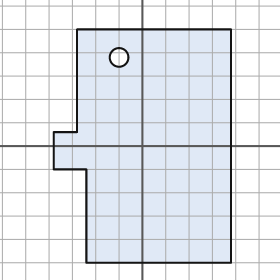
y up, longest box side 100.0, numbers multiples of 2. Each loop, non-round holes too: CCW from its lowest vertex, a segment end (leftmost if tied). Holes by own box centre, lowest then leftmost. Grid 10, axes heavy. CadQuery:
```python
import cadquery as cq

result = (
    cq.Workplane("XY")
    .moveTo(-24.0, -50.0)
    .lineTo(38.0, -50.0)
    .lineTo(38.0, 50.0)
    .lineTo(-28.0, 50.0)
    .lineTo(-28.0, 6.0)
    .lineTo(-38.0, 6.0)
    .lineTo(-38.0, -10.0)
    .lineTo(-24.0, -10.0)
    .close()
    .moveTo(-10.0, 38.0)
    .circle(4.0)
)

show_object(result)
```